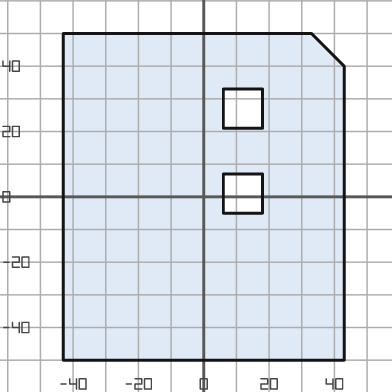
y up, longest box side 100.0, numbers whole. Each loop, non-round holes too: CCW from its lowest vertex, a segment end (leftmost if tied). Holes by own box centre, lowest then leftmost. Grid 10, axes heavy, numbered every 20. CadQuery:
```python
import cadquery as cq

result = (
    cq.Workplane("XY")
    .moveTo(-43.0, -50.0)
    .lineTo(43.0, -50.0)
    .lineTo(43.0, 40.0)
    .lineTo(33.0, 50.0)
    .lineTo(-43.0, 50.0)
    .close()
    .moveTo(6.0, -5.0)
    .lineTo(18.0, -5.0)
    .lineTo(18.0, 7.0)
    .lineTo(6.0, 7.0)
    .close()
    .moveTo(6.0, 21.0)
    .lineTo(18.0, 21.0)
    .lineTo(18.0, 33.0)
    .lineTo(6.0, 33.0)
    .close()
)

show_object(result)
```